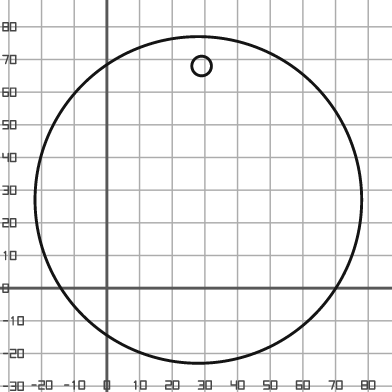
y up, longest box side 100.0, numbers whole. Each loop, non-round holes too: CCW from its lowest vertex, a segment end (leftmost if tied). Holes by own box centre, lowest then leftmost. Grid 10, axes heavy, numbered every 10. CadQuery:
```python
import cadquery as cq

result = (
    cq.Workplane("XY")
    .moveTo(28.0, 27.0)
    .circle(50.0)
    .moveTo(29.0, 68.0)
    .circle(3.0)
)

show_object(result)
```